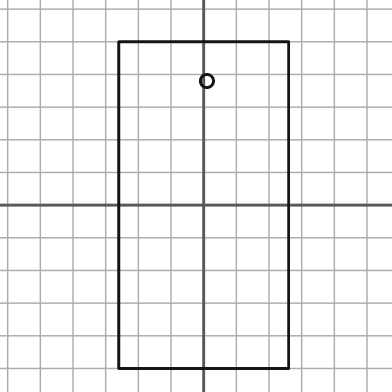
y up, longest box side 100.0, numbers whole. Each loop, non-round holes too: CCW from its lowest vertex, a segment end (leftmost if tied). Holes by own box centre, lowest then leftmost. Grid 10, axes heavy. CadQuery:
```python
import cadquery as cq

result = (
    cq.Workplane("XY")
    .moveTo(-26.0, -50.0)
    .lineTo(26.0, -50.0)
    .lineTo(26.0, 50.0)
    .lineTo(-26.0, 50.0)
    .close()
    .moveTo(1.0, 38.0)
    .circle(2.0)
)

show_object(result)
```